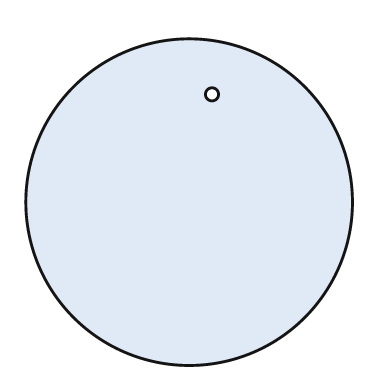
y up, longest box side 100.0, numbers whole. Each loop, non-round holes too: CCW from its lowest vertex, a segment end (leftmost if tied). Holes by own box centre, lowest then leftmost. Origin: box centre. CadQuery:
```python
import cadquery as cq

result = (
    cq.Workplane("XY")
    .moveTo(0.0, 0.0)
    .circle(50.0)
    .moveTo(7.0, 33.0)
    .circle(2.0)
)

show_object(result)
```